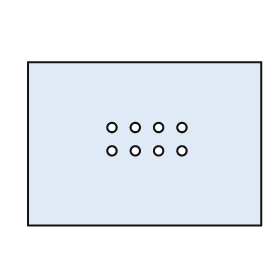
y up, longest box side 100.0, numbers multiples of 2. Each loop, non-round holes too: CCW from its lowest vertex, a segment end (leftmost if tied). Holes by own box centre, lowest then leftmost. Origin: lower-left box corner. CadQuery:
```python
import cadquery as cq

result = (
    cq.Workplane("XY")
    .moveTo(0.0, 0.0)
    .lineTo(100.0, 0.0)
    .lineTo(100.0, 70.0)
    .lineTo(0.0, 70.0)
    .close()
    .moveTo(36.0, 32.0)
    .circle(2.0)
    .moveTo(46.0, 32.0)
    .circle(2.0)
    .moveTo(56.0, 32.0)
    .circle(2.0)
    .moveTo(66.0, 32.0)
    .circle(2.0)
    .moveTo(36.0, 42.0)
    .circle(2.0)
    .moveTo(46.0, 42.0)
    .circle(2.0)
    .moveTo(56.0, 42.0)
    .circle(2.0)
    .moveTo(66.0, 42.0)
    .circle(2.0)
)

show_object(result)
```